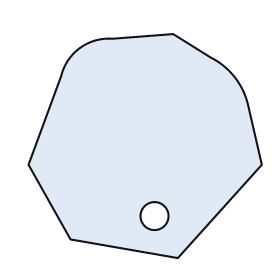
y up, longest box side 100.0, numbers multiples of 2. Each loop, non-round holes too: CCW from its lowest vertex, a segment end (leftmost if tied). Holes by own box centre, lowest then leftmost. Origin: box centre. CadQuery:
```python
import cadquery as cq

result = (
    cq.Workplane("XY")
    .moveTo(14.0, -48.0)
    .lineTo(50.0, -8.0)
    .lineTo(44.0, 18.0)
    .threePointArc((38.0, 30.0), (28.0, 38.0))
    .lineTo(12.0, 48.0)
    .lineTo(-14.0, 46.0)
    .threePointArc((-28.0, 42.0), (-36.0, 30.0))
    .lineTo(-50.0, -8.0)
    .lineTo(-32.0, -40.0)
    .close()
    .moveTo(4.0, -30.0)
    .circle(6.0)
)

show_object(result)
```